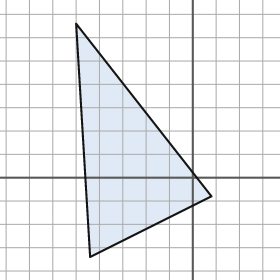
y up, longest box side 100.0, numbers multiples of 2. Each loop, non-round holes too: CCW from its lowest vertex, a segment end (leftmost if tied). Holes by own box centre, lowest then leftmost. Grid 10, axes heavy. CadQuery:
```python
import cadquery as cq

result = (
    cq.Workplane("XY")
    .moveTo(-44.0, -34.0)
    .lineTo(8.0, -8.0)
    .lineTo(-50.0, 66.0)
    .close()
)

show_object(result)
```